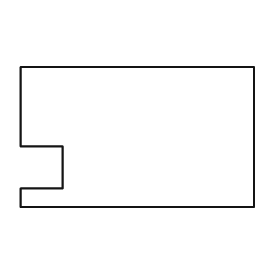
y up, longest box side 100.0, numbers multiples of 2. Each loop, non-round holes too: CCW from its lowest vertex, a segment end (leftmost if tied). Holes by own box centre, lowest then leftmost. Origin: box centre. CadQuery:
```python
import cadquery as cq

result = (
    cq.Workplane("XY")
    .moveTo(-50.0, -30.0)
    .lineTo(50.0, -30.0)
    .lineTo(50.0, 30.0)
    .lineTo(-50.0, 30.0)
    .lineTo(-50.0, -4.0)
    .lineTo(-32.0, -4.0)
    .lineTo(-32.0, -22.0)
    .lineTo(-50.0, -22.0)
    .close()
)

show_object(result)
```